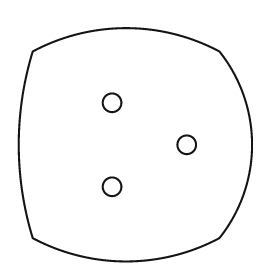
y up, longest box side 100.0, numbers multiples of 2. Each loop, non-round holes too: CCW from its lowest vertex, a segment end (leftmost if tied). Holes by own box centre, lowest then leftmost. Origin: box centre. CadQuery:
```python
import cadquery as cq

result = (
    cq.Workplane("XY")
    .moveTo(-44.0, -40.0)
    .threePointArc((-4.0, -50.0), (36.0, -40.0))
    .threePointArc((50.0, 0.0), (36.0, 40.0))
    .threePointArc((-4.0, 50.0), (-44.0, 40.0))
    .threePointArc((-50.0, 0.0), (-44.0, -40.0))
    .close()
    .moveTo(-10.0, -18.0)
    .circle(4.0)
    .moveTo(22.0, 0.0)
    .circle(4.0)
    .moveTo(-10.0, 18.0)
    .circle(4.0)
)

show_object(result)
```